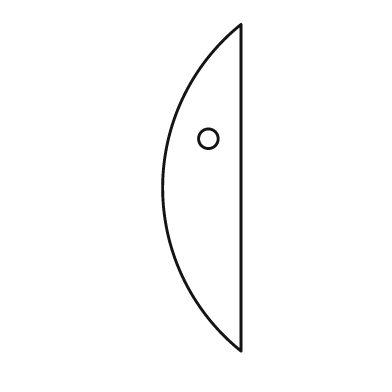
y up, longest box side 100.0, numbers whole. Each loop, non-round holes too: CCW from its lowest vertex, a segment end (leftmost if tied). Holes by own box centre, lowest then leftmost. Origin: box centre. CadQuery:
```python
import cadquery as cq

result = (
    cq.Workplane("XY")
    .moveTo(12.0, -50.0)
    .lineTo(12.0, 50.0)
    .threePointArc((-12.0, 0.0), (12.0, -50.0))
    .close()
    .moveTo(2.0, 15.0)
    .circle(3.0)
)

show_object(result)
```